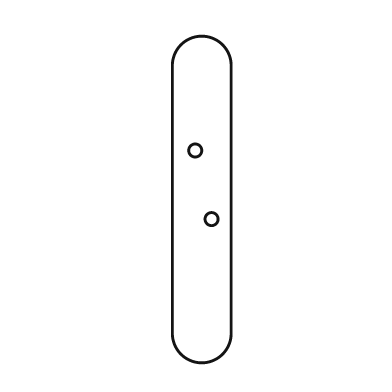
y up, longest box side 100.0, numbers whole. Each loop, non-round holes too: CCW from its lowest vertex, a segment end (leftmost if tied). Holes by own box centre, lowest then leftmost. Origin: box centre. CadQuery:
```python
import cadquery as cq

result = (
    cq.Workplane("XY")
    .moveTo(-9.0, -41.0)
    .threePointArc((0.0, -50.0), (9.0, -41.0))
    .lineTo(9.0, 41.0)
    .threePointArc((0.0, 50.0), (-9.0, 41.0))
    .close()
    .moveTo(3.0, -6.0)
    .circle(2.0)
    .moveTo(-2.0, 15.0)
    .circle(2.0)
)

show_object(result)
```